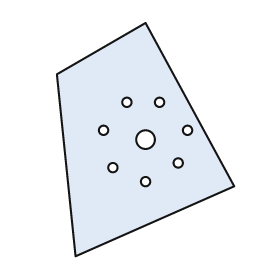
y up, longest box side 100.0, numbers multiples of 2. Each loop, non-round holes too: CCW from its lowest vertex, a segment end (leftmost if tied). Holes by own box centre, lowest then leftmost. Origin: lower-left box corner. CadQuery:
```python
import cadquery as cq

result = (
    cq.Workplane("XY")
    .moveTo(8.0, 0.0)
    .lineTo(76.0, 30.0)
    .lineTo(38.0, 100.0)
    .lineTo(0.0, 78.0)
    .close()
    .moveTo(38.0, 32.0)
    .circle(2.0)
    .moveTo(24.0, 38.0)
    .circle(2.0)
    .moveTo(52.0, 40.0)
    .circle(2.0)
    .moveTo(38.0, 50.0)
    .circle(4.0)
    .moveTo(20.0, 54.0)
    .circle(2.0)
    .moveTo(56.0, 54.0)
    .circle(2.0)
    .moveTo(30.0, 66.0)
    .circle(2.0)
    .moveTo(44.0, 66.0)
    .circle(2.0)
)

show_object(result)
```